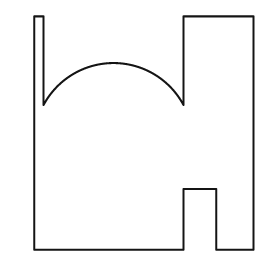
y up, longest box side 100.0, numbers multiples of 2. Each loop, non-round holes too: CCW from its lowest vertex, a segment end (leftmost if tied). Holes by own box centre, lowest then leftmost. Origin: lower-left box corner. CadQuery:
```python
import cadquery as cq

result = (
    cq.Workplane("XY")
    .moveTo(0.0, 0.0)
    .lineTo(64.0, 0.0)
    .lineTo(64.0, 26.0)
    .lineTo(78.0, 26.0)
    .lineTo(78.0, 0.0)
    .lineTo(94.0, 0.0)
    .lineTo(94.0, 100.0)
    .lineTo(64.0, 100.0)
    .lineTo(64.0, 62.0)
    .threePointArc((34.0, 80.0), (4.0, 62.0))
    .lineTo(4.0, 100.0)
    .lineTo(0.0, 100.0)
    .close()
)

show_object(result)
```